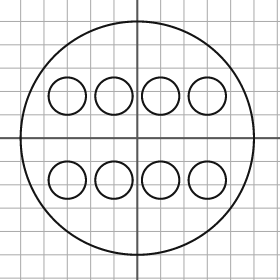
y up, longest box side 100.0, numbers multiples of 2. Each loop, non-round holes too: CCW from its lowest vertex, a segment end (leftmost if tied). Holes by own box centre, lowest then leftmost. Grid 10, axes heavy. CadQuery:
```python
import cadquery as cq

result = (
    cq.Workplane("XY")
    .moveTo(0.0, 0.0)
    .circle(50.0)
    .moveTo(-30.0, -18.0)
    .circle(8.0)
    .moveTo(-10.0, -18.0)
    .circle(8.0)
    .moveTo(10.0, -18.0)
    .circle(8.0)
    .moveTo(30.0, -18.0)
    .circle(8.0)
    .moveTo(-30.0, 18.0)
    .circle(8.0)
    .moveTo(-10.0, 18.0)
    .circle(8.0)
    .moveTo(10.0, 18.0)
    .circle(8.0)
    .moveTo(30.0, 18.0)
    .circle(8.0)
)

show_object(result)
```